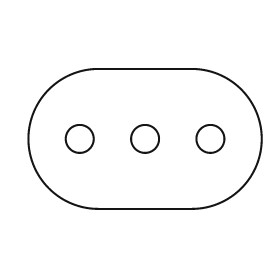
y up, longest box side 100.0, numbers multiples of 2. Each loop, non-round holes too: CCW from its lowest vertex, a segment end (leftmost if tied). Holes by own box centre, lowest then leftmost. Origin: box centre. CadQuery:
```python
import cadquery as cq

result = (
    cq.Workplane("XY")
    .moveTo(-20.0, -30.0)
    .lineTo(20.0, -30.0)
    .threePointArc((50.0, 0.0), (20.0, 30.0))
    .lineTo(-20.0, 30.0)
    .threePointArc((-50.0, 0.0), (-20.0, -30.0))
    .close()
    .moveTo(-28.0, 0.0)
    .circle(6.0)
    .moveTo(0.0, 0.0)
    .circle(6.0)
    .moveTo(28.0, 0.0)
    .circle(6.0)
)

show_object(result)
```